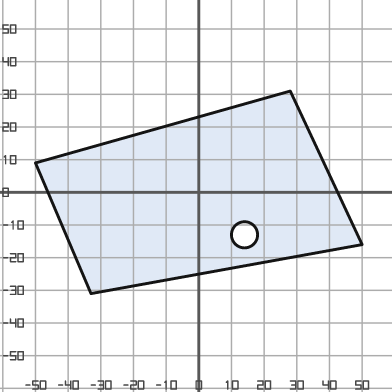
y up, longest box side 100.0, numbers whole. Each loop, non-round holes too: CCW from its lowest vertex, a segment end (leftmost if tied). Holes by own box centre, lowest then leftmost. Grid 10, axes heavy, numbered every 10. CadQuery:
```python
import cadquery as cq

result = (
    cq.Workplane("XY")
    .moveTo(-33.0, -31.0)
    .lineTo(50.0, -16.0)
    .lineTo(28.0, 31.0)
    .lineTo(-50.0, 9.0)
    .close()
    .moveTo(14.0, -13.0)
    .circle(4.0)
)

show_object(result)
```